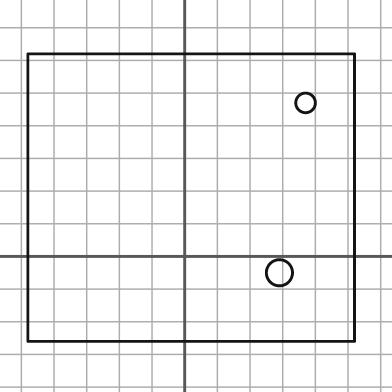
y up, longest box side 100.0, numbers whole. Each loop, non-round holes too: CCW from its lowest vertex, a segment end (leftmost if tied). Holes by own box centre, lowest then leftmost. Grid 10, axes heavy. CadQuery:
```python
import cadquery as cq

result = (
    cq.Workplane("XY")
    .moveTo(-48.0, -26.0)
    .lineTo(52.0, -26.0)
    .lineTo(52.0, 62.0)
    .lineTo(-48.0, 62.0)
    .close()
    .moveTo(29.0, -5.0)
    .circle(4.0)
    .moveTo(37.0, 47.0)
    .circle(3.0)
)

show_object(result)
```